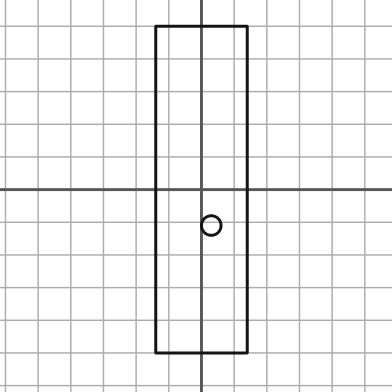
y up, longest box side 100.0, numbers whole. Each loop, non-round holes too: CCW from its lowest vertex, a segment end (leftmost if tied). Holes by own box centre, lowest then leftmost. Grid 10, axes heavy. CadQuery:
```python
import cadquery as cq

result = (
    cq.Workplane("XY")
    .moveTo(-14.0, -50.0)
    .lineTo(14.0, -50.0)
    .lineTo(14.0, 50.0)
    .lineTo(-14.0, 50.0)
    .close()
    .moveTo(3.0, -11.0)
    .circle(3.0)
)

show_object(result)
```